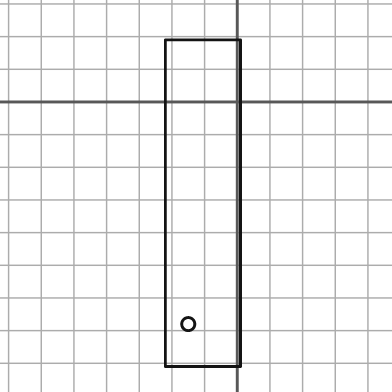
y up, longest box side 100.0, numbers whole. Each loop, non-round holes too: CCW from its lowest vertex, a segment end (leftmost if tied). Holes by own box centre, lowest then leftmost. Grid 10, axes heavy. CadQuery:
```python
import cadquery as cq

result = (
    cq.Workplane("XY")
    .moveTo(-22.0, -81.0)
    .lineTo(1.0, -81.0)
    .lineTo(1.0, 19.0)
    .lineTo(-22.0, 19.0)
    .close()
    .moveTo(-15.0, -68.0)
    .circle(2.0)
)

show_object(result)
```